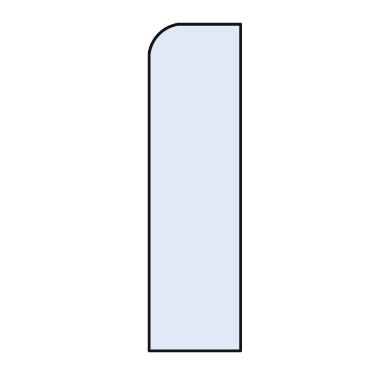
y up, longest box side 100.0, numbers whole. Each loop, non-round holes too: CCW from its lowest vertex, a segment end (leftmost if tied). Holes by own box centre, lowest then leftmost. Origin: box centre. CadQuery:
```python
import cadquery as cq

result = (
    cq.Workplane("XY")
    .moveTo(-14.0, -50.0)
    .lineTo(14.0, -50.0)
    .lineTo(14.0, 50.0)
    .lineTo(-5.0, 50.0)
    .threePointArc((-11.0, 47.0), (-14.0, 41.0))
    .close()
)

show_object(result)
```